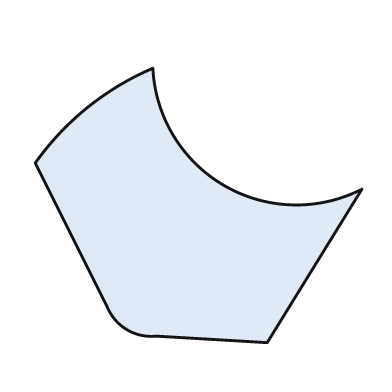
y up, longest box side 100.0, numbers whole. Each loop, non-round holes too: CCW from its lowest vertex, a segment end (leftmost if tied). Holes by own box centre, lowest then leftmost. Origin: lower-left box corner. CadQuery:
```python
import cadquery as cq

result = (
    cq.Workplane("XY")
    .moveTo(71.0, 0.0)
    .lineTo(100.0, 47.0)
    .threePointArc((58.0, 48.0), (36.0, 84.0))
    .threePointArc((16.0, 72.0), (0.0, 55.0))
    .lineTo(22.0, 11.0)
    .threePointArc((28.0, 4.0), (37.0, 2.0))
    .close()
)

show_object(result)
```